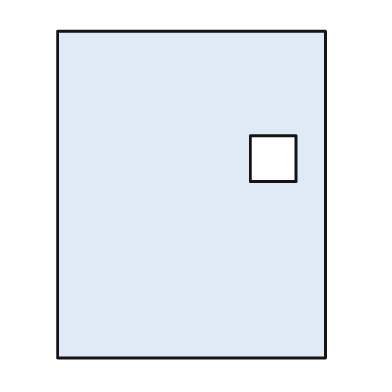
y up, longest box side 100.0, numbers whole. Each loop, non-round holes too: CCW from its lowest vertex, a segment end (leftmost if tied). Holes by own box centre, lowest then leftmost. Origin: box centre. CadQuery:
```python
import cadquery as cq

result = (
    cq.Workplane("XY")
    .moveTo(-41.0, -50.0)
    .lineTo(41.0, -50.0)
    .lineTo(41.0, 50.0)
    .lineTo(-41.0, 50.0)
    .close()
    .moveTo(18.0, 4.0)
    .lineTo(32.0, 4.0)
    .lineTo(32.0, 18.0)
    .lineTo(18.0, 18.0)
    .close()
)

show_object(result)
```